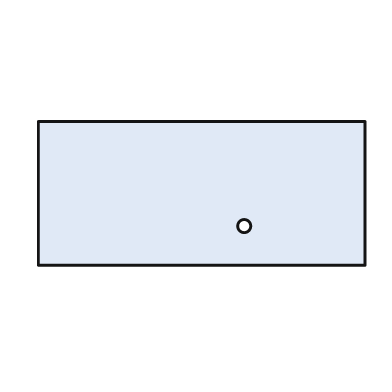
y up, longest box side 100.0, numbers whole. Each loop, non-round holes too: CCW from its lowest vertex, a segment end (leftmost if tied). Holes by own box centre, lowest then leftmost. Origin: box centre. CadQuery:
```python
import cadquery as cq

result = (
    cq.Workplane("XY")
    .moveTo(-50.0, -22.0)
    .lineTo(50.0, -22.0)
    .lineTo(50.0, 22.0)
    .lineTo(-50.0, 22.0)
    .close()
    .moveTo(13.0, -10.0)
    .circle(2.0)
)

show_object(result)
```